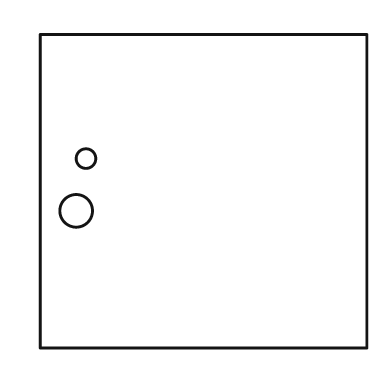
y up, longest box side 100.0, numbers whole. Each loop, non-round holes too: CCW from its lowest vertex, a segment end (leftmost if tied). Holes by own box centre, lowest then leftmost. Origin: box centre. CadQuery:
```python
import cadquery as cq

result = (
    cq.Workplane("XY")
    .moveTo(-50.0, -48.0)
    .lineTo(50.0, -48.0)
    .lineTo(50.0, 48.0)
    .lineTo(-50.0, 48.0)
    .close()
    .moveTo(-39.0, -6.0)
    .circle(5.0)
    .moveTo(-36.0, 10.0)
    .circle(3.0)
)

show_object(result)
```